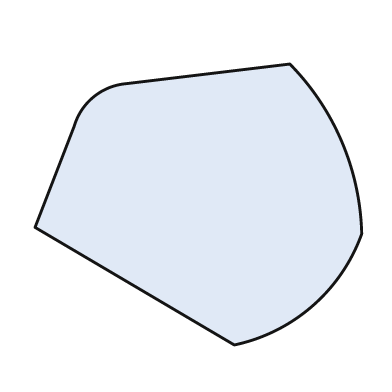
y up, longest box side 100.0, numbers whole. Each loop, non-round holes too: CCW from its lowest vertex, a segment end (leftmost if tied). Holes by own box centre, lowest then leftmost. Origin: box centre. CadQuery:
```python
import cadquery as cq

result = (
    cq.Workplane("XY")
    .moveTo(11.0, -43.0)
    .threePointArc((35.0, -31.0), (50.0, -9.0))
    .threePointArc((44.0, 19.0), (28.0, 43.0))
    .lineTo(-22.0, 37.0)
    .threePointArc((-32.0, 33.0), (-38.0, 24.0))
    .lineTo(-50.0, -7.0)
    .close()
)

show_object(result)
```